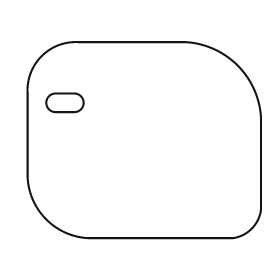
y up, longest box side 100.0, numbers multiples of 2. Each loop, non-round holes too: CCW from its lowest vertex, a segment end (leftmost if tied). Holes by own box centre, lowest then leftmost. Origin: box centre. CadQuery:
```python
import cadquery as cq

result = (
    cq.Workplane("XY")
    .moveTo(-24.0, -42.0)
    .lineTo(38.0, -42.0)
    .threePointArc((46.0, -38.0), (50.0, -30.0))
    .lineTo(50.0, 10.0)
    .threePointArc((40.0, 32.0), (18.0, 42.0))
    .lineTo(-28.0, 42.0)
    .threePointArc((-44.0, 36.0), (-50.0, 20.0))
    .lineTo(-50.0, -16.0)
    .threePointArc((-42.0, -34.0), (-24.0, -42.0))
    .close()
    .moveTo(-38.0, 12.0)
    .lineTo(-30.0, 12.0)
    .threePointArc((-26.0, 16.0), (-30.0, 20.0))
    .lineTo(-38.0, 20.0)
    .threePointArc((-42.0, 16.0), (-38.0, 12.0))
    .close()
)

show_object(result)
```